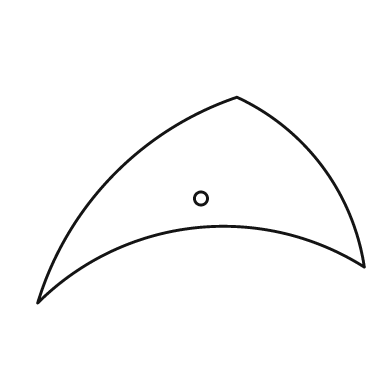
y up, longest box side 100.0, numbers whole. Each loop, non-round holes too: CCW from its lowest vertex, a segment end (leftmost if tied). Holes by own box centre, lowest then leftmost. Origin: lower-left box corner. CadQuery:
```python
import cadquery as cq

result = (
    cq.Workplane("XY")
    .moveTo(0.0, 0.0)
    .threePointArc((48.0, 23.0), (100.0, 11.0))
    .threePointArc((87.0, 42.0), (61.0, 63.0))
    .threePointArc((23.0, 39.0), (0.0, 0.0))
    .close()
    .moveTo(50.0, 32.0)
    .circle(2.0)
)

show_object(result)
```